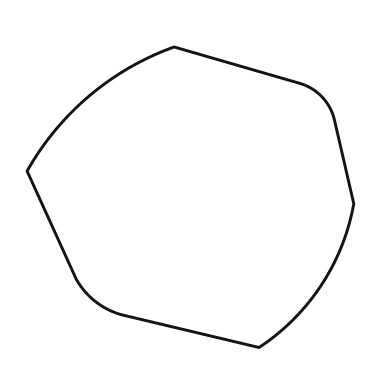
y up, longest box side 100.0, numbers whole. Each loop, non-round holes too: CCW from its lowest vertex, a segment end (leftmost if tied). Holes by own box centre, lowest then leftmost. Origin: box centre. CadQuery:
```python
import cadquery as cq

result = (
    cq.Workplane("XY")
    .moveTo(21.0, -46.0)
    .threePointArc((40.0, -27.0), (50.0, -2.0))
    .lineTo(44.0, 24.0)
    .threePointArc((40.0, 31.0), (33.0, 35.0))
    .lineTo(-5.0, 46.0)
    .threePointArc((-31.0, 31.0), (-50.0, 8.0))
    .lineTo(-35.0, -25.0)
    .threePointArc((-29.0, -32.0), (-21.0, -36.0))
    .close()
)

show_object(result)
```